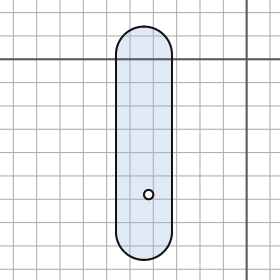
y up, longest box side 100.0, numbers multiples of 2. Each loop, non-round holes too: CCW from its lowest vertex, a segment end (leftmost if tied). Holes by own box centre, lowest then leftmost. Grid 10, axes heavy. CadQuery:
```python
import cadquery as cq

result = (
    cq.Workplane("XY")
    .moveTo(-56.0, -74.0)
    .threePointArc((-44.0, -86.0), (-32.0, -74.0))
    .lineTo(-32.0, 2.0)
    .threePointArc((-44.0, 14.0), (-56.0, 2.0))
    .close()
    .moveTo(-42.0, -58.0)
    .circle(2.0)
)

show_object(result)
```